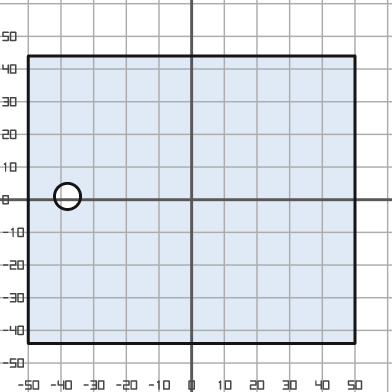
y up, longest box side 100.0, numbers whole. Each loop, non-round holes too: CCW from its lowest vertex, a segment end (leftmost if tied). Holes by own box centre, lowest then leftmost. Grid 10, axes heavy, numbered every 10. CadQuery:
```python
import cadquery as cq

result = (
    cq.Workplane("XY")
    .moveTo(-50.0, -44.0)
    .lineTo(50.0, -44.0)
    .lineTo(50.0, 44.0)
    .lineTo(-50.0, 44.0)
    .close()
    .moveTo(-38.0, 1.0)
    .circle(4.0)
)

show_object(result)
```